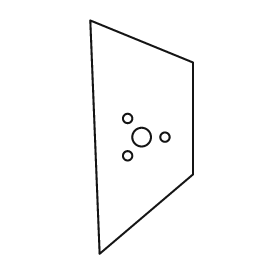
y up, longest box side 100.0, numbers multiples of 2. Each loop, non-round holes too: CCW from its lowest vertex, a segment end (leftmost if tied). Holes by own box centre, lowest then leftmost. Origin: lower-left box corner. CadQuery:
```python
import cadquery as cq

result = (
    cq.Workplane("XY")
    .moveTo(4.0, 0.0)
    .lineTo(44.0, 34.0)
    .lineTo(44.0, 82.0)
    .lineTo(0.0, 100.0)
    .close()
    .moveTo(16.0, 42.0)
    .circle(2.0)
    .moveTo(22.0, 50.0)
    .circle(4.0)
    .moveTo(32.0, 50.0)
    .circle(2.0)
    .moveTo(16.0, 58.0)
    .circle(2.0)
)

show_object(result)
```